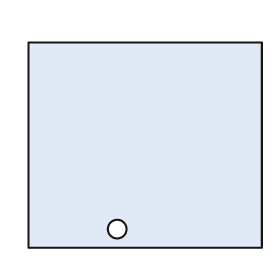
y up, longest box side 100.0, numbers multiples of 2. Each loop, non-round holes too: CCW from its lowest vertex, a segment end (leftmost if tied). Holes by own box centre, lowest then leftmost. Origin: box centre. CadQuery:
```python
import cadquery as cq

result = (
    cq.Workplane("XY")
    .moveTo(-50.0, -44.0)
    .lineTo(50.0, -44.0)
    .lineTo(50.0, 44.0)
    .lineTo(-50.0, 44.0)
    .close()
    .moveTo(-12.0, -36.0)
    .circle(4.0)
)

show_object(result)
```